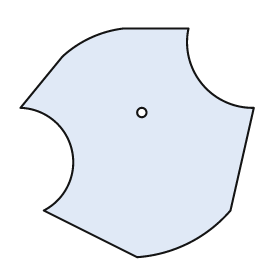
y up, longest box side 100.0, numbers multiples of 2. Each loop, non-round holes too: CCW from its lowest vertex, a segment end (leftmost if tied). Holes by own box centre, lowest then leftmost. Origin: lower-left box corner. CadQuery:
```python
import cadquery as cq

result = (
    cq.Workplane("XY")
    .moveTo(50.0, 0.0)
    .threePointArc((72.0, 6.0), (90.0, 20.0))
    .lineTo(100.0, 64.0)
    .threePointArc((78.0, 74.0), (72.0, 98.0))
    .lineTo(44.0, 98.0)
    .threePointArc((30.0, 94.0), (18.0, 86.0))
    .lineTo(0.0, 64.0)
    .threePointArc((22.0, 46.0), (10.0, 20.0))
    .close()
    .moveTo(52.0, 62.0)
    .circle(2.0)
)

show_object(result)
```